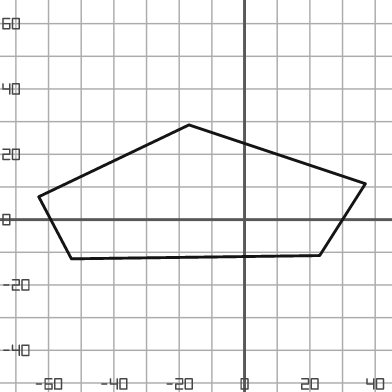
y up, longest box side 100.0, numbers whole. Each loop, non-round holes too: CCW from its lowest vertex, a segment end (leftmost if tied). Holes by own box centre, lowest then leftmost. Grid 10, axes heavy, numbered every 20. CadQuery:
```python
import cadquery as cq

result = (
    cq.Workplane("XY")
    .moveTo(-53.0, -12.0)
    .lineTo(23.0, -11.0)
    .lineTo(37.0, 11.0)
    .lineTo(-17.0, 29.0)
    .lineTo(-63.0, 7.0)
    .close()
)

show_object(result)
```